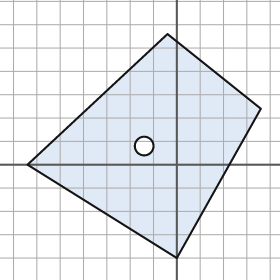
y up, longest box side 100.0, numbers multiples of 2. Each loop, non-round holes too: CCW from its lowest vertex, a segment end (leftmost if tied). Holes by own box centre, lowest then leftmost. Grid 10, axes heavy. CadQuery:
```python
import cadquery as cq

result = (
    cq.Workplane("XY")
    .moveTo(0.0, -40.0)
    .lineTo(36.0, 24.0)
    .lineTo(-4.0, 56.0)
    .lineTo(-64.0, 0.0)
    .close()
    .moveTo(-14.0, 8.0)
    .circle(4.0)
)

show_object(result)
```